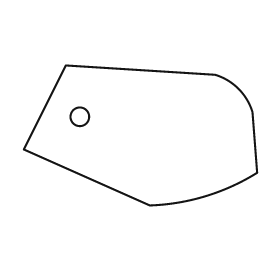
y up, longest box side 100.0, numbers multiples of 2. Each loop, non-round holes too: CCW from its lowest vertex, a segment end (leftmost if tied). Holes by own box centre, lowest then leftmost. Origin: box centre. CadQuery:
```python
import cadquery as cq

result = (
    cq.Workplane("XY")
    .moveTo(4.0, -30.0)
    .threePointArc((28.0, -26.0), (50.0, -16.0))
    .lineTo(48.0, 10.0)
    .threePointArc((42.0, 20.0), (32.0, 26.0))
    .lineTo(-32.0, 30.0)
    .lineTo(-50.0, -6.0)
    .close()
    .moveTo(-26.0, 8.0)
    .circle(4.0)
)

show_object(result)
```